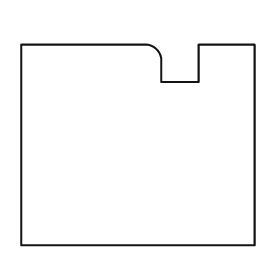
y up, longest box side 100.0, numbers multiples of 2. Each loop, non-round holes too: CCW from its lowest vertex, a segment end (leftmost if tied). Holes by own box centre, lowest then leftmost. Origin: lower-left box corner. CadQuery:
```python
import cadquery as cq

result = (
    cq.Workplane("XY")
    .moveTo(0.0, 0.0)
    .lineTo(100.0, 0.0)
    .lineTo(100.0, 86.0)
    .lineTo(76.0, 86.0)
    .lineTo(76.0, 70.0)
    .lineTo(60.0, 70.0)
    .lineTo(60.0, 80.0)
    .threePointArc((58.0, 84.0), (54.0, 86.0))
    .lineTo(0.0, 86.0)
    .close()
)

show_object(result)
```